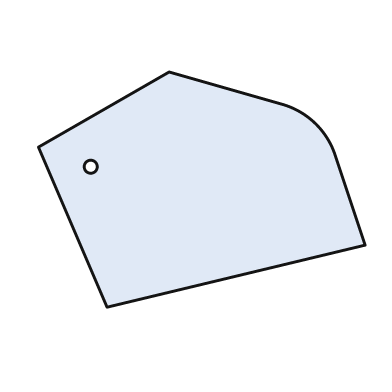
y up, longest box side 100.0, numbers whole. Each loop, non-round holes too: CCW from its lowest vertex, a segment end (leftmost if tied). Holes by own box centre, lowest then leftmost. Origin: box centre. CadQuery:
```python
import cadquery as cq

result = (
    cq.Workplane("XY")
    .moveTo(-29.0, -36.0)
    .lineTo(50.0, -17.0)
    .lineTo(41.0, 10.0)
    .threePointArc((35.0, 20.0), (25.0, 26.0))
    .lineTo(-10.0, 36.0)
    .lineTo(-50.0, 13.0)
    .close()
    .moveTo(-34.0, 7.0)
    .circle(2.0)
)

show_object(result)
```